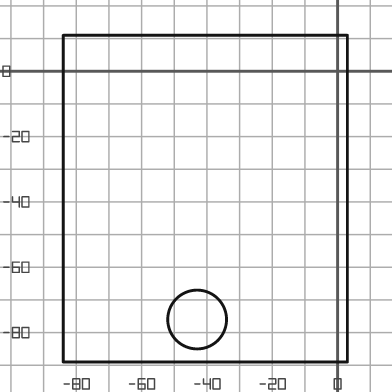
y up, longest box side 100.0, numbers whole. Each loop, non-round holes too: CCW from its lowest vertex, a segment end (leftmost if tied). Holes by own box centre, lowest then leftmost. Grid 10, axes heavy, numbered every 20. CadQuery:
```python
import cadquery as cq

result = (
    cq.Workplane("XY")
    .moveTo(-84.0, -89.0)
    .lineTo(3.0, -89.0)
    .lineTo(3.0, 11.0)
    .lineTo(-84.0, 11.0)
    .close()
    .moveTo(-43.0, -76.0)
    .circle(9.0)
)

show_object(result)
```